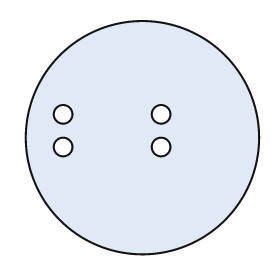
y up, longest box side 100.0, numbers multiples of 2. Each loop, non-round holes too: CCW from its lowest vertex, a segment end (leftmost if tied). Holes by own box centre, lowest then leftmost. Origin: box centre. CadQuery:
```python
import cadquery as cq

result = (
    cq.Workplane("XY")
    .moveTo(0.0, 0.0)
    .circle(50.0)
    .moveTo(-34.0, -4.0)
    .circle(4.0)
    .moveTo(8.0, -4.0)
    .circle(4.0)
    .moveTo(-34.0, 10.0)
    .circle(4.0)
    .moveTo(8.0, 10.0)
    .circle(4.0)
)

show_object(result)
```